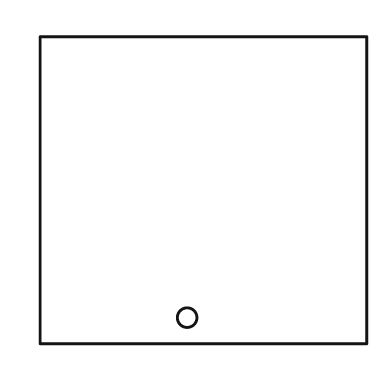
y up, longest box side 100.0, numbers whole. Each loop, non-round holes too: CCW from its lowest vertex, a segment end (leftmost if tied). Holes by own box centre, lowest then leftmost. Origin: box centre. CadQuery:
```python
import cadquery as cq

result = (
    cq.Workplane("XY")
    .moveTo(-50.0, -47.0)
    .lineTo(50.0, -47.0)
    .lineTo(50.0, 47.0)
    .lineTo(-50.0, 47.0)
    .close()
    .moveTo(-5.0, -39.0)
    .circle(3.0)
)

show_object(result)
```